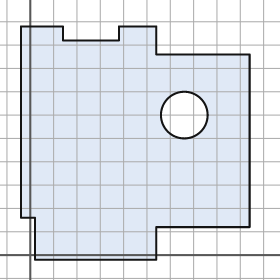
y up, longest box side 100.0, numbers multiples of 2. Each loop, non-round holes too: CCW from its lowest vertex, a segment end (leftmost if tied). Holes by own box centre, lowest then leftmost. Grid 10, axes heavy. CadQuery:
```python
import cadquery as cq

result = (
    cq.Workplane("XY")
    .moveTo(2.0, -2.0)
    .lineTo(54.0, -2.0)
    .lineTo(54.0, 12.0)
    .lineTo(94.0, 12.0)
    .lineTo(94.0, 86.0)
    .lineTo(54.0, 86.0)
    .lineTo(54.0, 98.0)
    .lineTo(38.0, 98.0)
    .lineTo(38.0, 92.0)
    .lineTo(14.0, 92.0)
    .lineTo(14.0, 98.0)
    .lineTo(-4.0, 98.0)
    .lineTo(-4.0, 16.0)
    .lineTo(2.0, 16.0)
    .close()
    .moveTo(66.0, 60.0)
    .circle(10.0)
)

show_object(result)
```